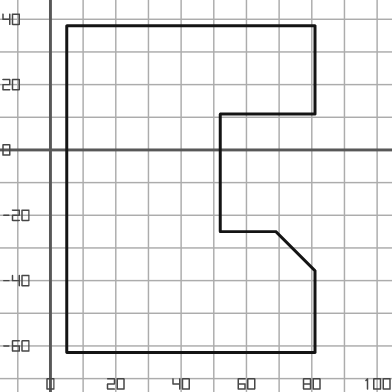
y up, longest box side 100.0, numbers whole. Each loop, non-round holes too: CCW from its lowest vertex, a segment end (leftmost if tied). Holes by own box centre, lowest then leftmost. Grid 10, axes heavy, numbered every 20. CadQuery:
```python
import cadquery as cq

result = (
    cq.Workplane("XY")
    .moveTo(5.0, -62.0)
    .lineTo(81.0, -62.0)
    .lineTo(81.0, -37.0)
    .lineTo(69.0, -25.0)
    .lineTo(52.0, -25.0)
    .lineTo(52.0, 11.0)
    .lineTo(81.0, 11.0)
    .lineTo(81.0, 38.0)
    .lineTo(5.0, 38.0)
    .close()
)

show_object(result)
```